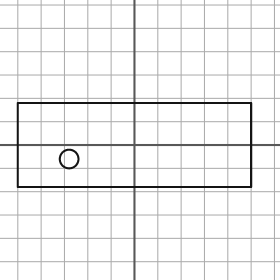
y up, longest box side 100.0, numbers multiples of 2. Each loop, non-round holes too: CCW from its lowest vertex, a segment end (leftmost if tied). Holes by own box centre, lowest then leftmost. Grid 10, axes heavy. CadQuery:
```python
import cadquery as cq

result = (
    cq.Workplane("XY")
    .moveTo(-50.0, -18.0)
    .lineTo(50.0, -18.0)
    .lineTo(50.0, 18.0)
    .lineTo(-50.0, 18.0)
    .close()
    .moveTo(-28.0, -6.0)
    .circle(4.0)
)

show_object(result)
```